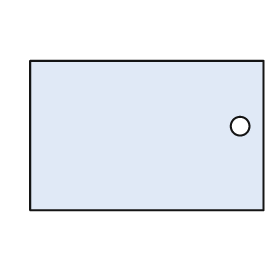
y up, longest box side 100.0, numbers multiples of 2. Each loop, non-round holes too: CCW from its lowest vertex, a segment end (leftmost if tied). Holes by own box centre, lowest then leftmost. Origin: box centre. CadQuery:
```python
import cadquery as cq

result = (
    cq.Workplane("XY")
    .moveTo(-50.0, -32.0)
    .lineTo(50.0, -32.0)
    .lineTo(50.0, 32.0)
    .lineTo(-50.0, 32.0)
    .close()
    .moveTo(40.0, 4.0)
    .circle(4.0)
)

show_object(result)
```